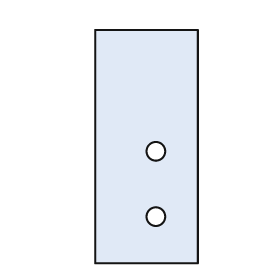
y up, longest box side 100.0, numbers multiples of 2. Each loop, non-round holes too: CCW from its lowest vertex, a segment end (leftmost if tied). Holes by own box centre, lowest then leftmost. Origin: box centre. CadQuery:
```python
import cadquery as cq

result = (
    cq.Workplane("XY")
    .moveTo(-22.0, -50.0)
    .lineTo(22.0, -50.0)
    .lineTo(22.0, 50.0)
    .lineTo(-22.0, 50.0)
    .close()
    .moveTo(4.0, -30.0)
    .circle(4.0)
    .moveTo(4.0, -2.0)
    .circle(4.0)
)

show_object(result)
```